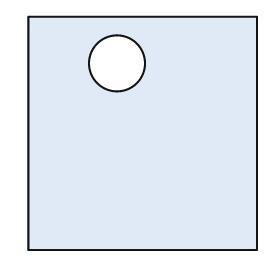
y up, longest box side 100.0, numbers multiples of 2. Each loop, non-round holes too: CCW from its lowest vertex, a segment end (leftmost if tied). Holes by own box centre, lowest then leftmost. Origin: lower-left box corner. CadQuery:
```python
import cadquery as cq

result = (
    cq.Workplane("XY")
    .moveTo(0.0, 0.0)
    .lineTo(98.0, 0.0)
    .lineTo(98.0, 100.0)
    .lineTo(0.0, 100.0)
    .close()
    .moveTo(38.0, 80.0)
    .circle(12.0)
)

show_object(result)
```